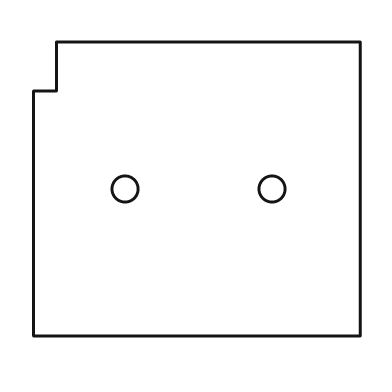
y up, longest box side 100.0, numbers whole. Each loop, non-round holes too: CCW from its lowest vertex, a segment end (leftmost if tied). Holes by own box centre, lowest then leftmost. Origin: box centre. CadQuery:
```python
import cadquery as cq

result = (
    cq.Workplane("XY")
    .moveTo(-50.0, -45.0)
    .lineTo(50.0, -45.0)
    .lineTo(50.0, 45.0)
    .lineTo(-43.0, 45.0)
    .lineTo(-43.0, 30.0)
    .lineTo(-50.0, 30.0)
    .close()
    .moveTo(-22.0, 0.0)
    .circle(4.0)
    .moveTo(23.0, 0.0)
    .circle(4.0)
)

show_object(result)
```